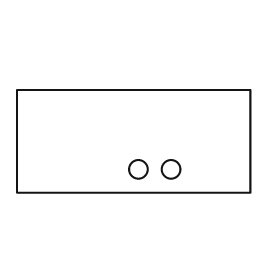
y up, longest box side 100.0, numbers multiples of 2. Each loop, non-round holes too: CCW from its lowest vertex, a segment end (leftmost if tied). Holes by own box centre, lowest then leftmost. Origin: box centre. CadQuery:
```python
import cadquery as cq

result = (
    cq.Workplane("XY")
    .moveTo(-50.0, -22.0)
    .lineTo(50.0, -22.0)
    .lineTo(50.0, 22.0)
    .lineTo(-50.0, 22.0)
    .close()
    .moveTo(2.0, -12.0)
    .circle(4.0)
    .moveTo(16.0, -12.0)
    .circle(4.0)
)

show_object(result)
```